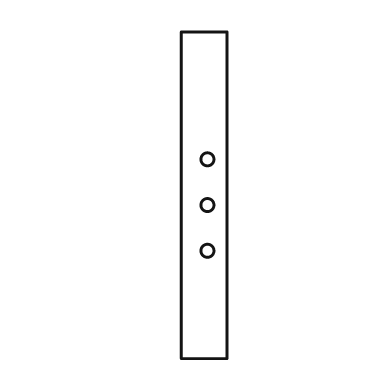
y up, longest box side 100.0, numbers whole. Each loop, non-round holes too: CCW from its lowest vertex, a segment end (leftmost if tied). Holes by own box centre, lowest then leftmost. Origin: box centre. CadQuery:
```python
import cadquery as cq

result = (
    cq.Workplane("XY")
    .moveTo(-7.0, -50.0)
    .lineTo(7.0, -50.0)
    .lineTo(7.0, 50.0)
    .lineTo(-7.0, 50.0)
    .close()
    .moveTo(1.0, -17.0)
    .circle(2.0)
    .moveTo(1.0, -3.0)
    .circle(2.0)
    .moveTo(1.0, 11.0)
    .circle(2.0)
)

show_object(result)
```